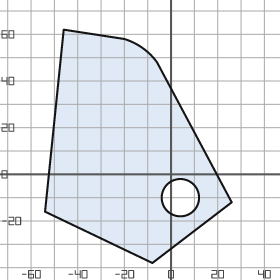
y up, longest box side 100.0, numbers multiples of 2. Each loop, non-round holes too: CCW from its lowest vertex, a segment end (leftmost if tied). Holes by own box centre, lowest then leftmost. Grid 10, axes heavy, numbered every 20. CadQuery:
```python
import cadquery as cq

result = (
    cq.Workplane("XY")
    .moveTo(-8.0, -38.0)
    .lineTo(26.0, -12.0)
    .lineTo(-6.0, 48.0)
    .threePointArc((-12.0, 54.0), (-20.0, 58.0))
    .lineTo(-46.0, 62.0)
    .lineTo(-54.0, -16.0)
    .close()
    .moveTo(4.0, -10.0)
    .circle(8.0)
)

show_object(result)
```